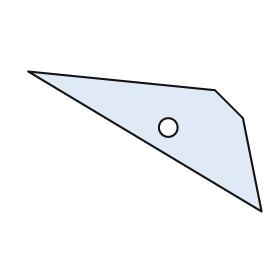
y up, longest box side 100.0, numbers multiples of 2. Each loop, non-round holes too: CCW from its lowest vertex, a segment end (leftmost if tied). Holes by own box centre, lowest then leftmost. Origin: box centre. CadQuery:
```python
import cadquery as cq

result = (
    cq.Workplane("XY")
    .moveTo(50.0, -30.0)
    .lineTo(42.0, 10.0)
    .lineTo(30.0, 22.0)
    .lineTo(-50.0, 30.0)
    .close()
    .moveTo(10.0, 6.0)
    .circle(4.0)
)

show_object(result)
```